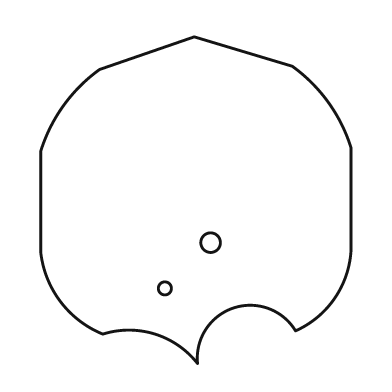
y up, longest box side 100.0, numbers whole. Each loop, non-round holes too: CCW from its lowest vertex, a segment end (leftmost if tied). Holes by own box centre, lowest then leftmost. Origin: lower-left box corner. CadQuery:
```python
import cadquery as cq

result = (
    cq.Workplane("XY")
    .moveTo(48.0, 0.0)
    .threePointArc((59.0, 17.0), (78.0, 10.0))
    .threePointArc((90.0, 20.0), (95.0, 35.0))
    .lineTo(95.0, 66.0)
    .threePointArc((88.0, 80.0), (77.0, 91.0))
    .lineTo(47.0, 100.0)
    .lineTo(18.0, 90.0)
    .threePointArc((7.0, 79.0), (0.0, 65.0))
    .lineTo(0.0, 34.0)
    .threePointArc((6.0, 19.0), (19.0, 9.0))
    .threePointArc((35.0, 9.0), (48.0, 0.0))
    .close()
    .moveTo(38.0, 23.0)
    .circle(2.0)
    .moveTo(52.0, 37.0)
    .circle(3.0)
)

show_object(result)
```